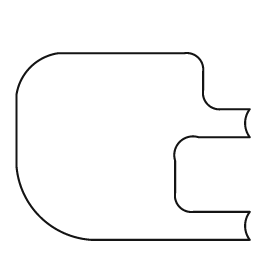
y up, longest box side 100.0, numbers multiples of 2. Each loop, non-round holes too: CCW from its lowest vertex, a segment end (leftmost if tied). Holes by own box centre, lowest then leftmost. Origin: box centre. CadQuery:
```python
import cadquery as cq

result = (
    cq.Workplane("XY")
    .moveTo(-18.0, -40.0)
    .lineTo(50.0, -40.0)
    .threePointArc((48.0, -34.0), (50.0, -28.0))
    .lineTo(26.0, -28.0)
    .threePointArc((20.0, -26.0), (18.0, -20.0))
    .lineTo(18.0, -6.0)
    .threePointArc((20.0, 2.0), (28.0, 4.0))
    .lineTo(50.0, 4.0)
    .threePointArc((48.0, 10.0), (50.0, 16.0))
    .lineTo(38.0, 16.0)
    .threePointArc((32.0, 18.0), (30.0, 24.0))
    .lineTo(30.0, 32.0)
    .threePointArc((28.0, 38.0), (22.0, 40.0))
    .lineTo(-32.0, 40.0)
    .threePointArc((-44.0, 34.0), (-50.0, 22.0))
    .lineTo(-50.0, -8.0)
    .threePointArc((-40.0, -30.0), (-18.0, -40.0))
    .close()
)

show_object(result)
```